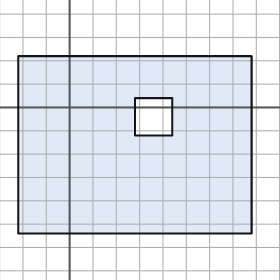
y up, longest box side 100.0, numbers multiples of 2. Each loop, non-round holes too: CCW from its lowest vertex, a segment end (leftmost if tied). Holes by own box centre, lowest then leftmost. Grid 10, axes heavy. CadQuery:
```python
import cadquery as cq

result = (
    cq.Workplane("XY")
    .moveTo(-22.0, -54.0)
    .lineTo(78.0, -54.0)
    .lineTo(78.0, 22.0)
    .lineTo(-22.0, 22.0)
    .close()
    .moveTo(28.0, -12.0)
    .lineTo(44.0, -12.0)
    .lineTo(44.0, 4.0)
    .lineTo(28.0, 4.0)
    .close()
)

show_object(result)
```